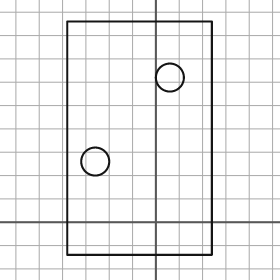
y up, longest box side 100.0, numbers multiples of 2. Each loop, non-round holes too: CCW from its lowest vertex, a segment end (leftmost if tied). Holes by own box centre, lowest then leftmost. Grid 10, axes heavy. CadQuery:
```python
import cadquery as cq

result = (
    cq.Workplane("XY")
    .moveTo(-38.0, -14.0)
    .lineTo(24.0, -14.0)
    .lineTo(24.0, 86.0)
    .lineTo(-38.0, 86.0)
    .close()
    .moveTo(-26.0, 26.0)
    .circle(6.0)
    .moveTo(6.0, 62.0)
    .circle(6.0)
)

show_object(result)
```